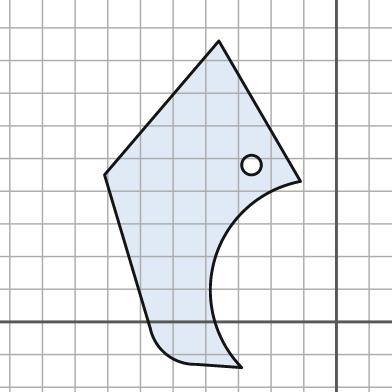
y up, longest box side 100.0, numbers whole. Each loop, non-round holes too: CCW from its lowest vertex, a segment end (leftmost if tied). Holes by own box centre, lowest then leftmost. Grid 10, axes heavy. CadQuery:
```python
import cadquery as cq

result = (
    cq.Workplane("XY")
    .moveTo(-29.0, -14.0)
    .threePointArc((-37.0, 20.0), (-11.0, 43.0))
    .lineTo(-36.0, 86.0)
    .lineTo(-71.0, 45.0)
    .lineTo(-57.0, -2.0)
    .threePointArc((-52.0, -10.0), (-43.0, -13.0))
    .close()
    .moveTo(-26.0, 48.0)
    .circle(3.0)
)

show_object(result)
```